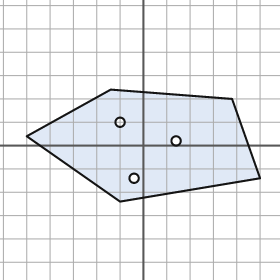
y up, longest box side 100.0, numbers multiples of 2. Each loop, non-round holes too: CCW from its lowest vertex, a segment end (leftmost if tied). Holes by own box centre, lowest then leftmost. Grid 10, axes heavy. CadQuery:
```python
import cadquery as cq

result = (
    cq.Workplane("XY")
    .moveTo(-10.0, -24.0)
    .lineTo(50.0, -14.0)
    .lineTo(38.0, 20.0)
    .lineTo(-14.0, 24.0)
    .lineTo(-50.0, 4.0)
    .close()
    .moveTo(-4.0, -14.0)
    .circle(2.0)
    .moveTo(14.0, 2.0)
    .circle(2.0)
    .moveTo(-10.0, 10.0)
    .circle(2.0)
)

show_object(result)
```